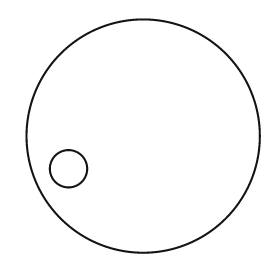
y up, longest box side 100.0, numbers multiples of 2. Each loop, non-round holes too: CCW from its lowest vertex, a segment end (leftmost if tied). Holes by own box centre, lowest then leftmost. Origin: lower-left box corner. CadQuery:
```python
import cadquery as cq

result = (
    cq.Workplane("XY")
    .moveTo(50.0, 50.0)
    .circle(50.0)
    .moveTo(18.0, 36.0)
    .circle(8.0)
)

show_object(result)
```